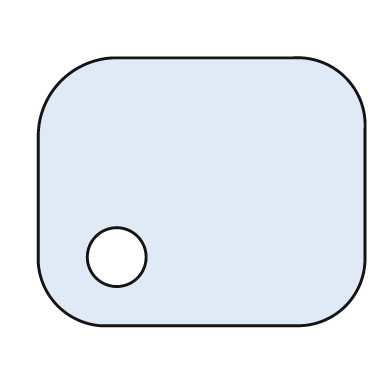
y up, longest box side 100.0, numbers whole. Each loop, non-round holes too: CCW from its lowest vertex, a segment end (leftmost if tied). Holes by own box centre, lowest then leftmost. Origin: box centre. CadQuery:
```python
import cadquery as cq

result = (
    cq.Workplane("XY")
    .moveTo(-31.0, -41.0)
    .lineTo(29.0, -41.0)
    .threePointArc((44.0, -35.0), (50.0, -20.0))
    .lineTo(50.0, 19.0)
    .threePointArc((44.0, 35.0), (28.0, 41.0))
    .lineTo(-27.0, 41.0)
    .threePointArc((-43.0, 34.0), (-50.0, 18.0))
    .lineTo(-50.0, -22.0)
    .threePointArc((-44.0, -35.0), (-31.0, -41.0))
    .close()
    .moveTo(-26.0, -20.0)
    .circle(9.0)
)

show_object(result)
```